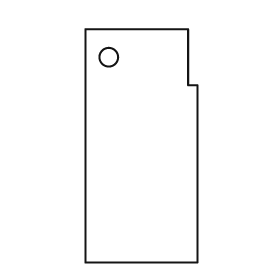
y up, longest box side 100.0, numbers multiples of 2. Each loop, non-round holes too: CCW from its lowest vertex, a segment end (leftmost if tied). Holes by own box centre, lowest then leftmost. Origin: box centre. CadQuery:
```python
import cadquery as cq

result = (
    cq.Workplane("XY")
    .moveTo(-24.0, -50.0)
    .lineTo(24.0, -50.0)
    .lineTo(24.0, 26.0)
    .lineTo(20.0, 26.0)
    .lineTo(20.0, 50.0)
    .lineTo(-24.0, 50.0)
    .close()
    .moveTo(-14.0, 38.0)
    .circle(4.0)
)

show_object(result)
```